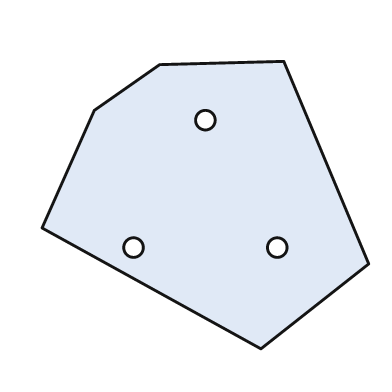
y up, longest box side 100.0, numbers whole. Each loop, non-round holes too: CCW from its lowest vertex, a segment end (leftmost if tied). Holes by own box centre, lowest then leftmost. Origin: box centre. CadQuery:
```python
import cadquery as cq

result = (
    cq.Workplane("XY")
    .moveTo(17.0, -44.0)
    .lineTo(50.0, -18.0)
    .lineTo(24.0, 44.0)
    .lineTo(-14.0, 43.0)
    .lineTo(-34.0, 29.0)
    .lineTo(-50.0, -7.0)
    .close()
    .moveTo(-22.0, -13.0)
    .circle(3.0)
    .moveTo(22.0, -13.0)
    .circle(3.0)
    .moveTo(0.0, 26.0)
    .circle(3.0)
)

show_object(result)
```